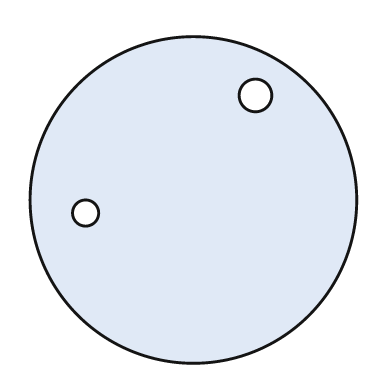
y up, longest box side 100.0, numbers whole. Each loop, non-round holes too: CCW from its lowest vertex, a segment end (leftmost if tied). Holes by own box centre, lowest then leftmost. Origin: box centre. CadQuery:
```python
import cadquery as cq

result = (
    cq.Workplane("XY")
    .moveTo(0.0, 0.0)
    .circle(50.0)
    .moveTo(-33.0, -4.0)
    .circle(4.0)
    .moveTo(19.0, 32.0)
    .circle(5.0)
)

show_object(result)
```